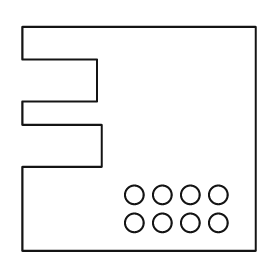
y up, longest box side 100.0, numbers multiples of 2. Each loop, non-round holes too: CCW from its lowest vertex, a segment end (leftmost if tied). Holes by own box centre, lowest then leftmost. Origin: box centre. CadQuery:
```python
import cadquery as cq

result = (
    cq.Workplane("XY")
    .moveTo(-50.0, -48.0)
    .lineTo(50.0, -48.0)
    .lineTo(50.0, 48.0)
    .lineTo(-50.0, 48.0)
    .lineTo(-50.0, 34.0)
    .lineTo(-18.0, 34.0)
    .lineTo(-18.0, 16.0)
    .lineTo(-50.0, 16.0)
    .lineTo(-50.0, 6.0)
    .lineTo(-16.0, 6.0)
    .lineTo(-16.0, -12.0)
    .lineTo(-50.0, -12.0)
    .close()
    .moveTo(-2.0, -36.0)
    .circle(4.0)
    .moveTo(10.0, -36.0)
    .circle(4.0)
    .moveTo(22.0, -36.0)
    .circle(4.0)
    .moveTo(34.0, -36.0)
    .circle(4.0)
    .moveTo(-2.0, -24.0)
    .circle(4.0)
    .moveTo(10.0, -24.0)
    .circle(4.0)
    .moveTo(22.0, -24.0)
    .circle(4.0)
    .moveTo(34.0, -24.0)
    .circle(4.0)
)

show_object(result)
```